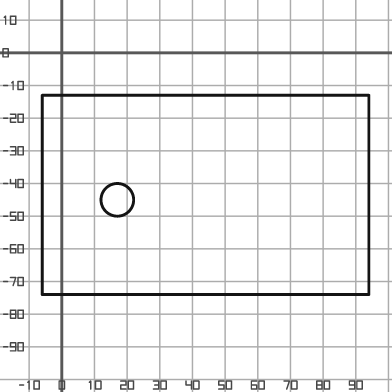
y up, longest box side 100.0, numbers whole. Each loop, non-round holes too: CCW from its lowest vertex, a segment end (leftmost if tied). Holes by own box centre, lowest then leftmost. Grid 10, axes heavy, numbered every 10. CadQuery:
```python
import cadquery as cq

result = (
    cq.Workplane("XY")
    .moveTo(-6.0, -74.0)
    .lineTo(94.0, -74.0)
    .lineTo(94.0, -13.0)
    .lineTo(-6.0, -13.0)
    .close()
    .moveTo(17.0, -45.0)
    .circle(5.0)
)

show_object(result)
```